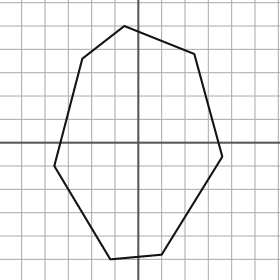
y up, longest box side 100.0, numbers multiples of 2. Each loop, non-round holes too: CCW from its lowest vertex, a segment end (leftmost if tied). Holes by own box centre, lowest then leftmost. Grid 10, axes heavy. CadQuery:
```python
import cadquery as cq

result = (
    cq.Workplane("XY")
    .moveTo(-12.0, -50.0)
    .lineTo(10.0, -48.0)
    .lineTo(36.0, -6.0)
    .lineTo(24.0, 38.0)
    .lineTo(-6.0, 50.0)
    .lineTo(-24.0, 36.0)
    .lineTo(-36.0, -10.0)
    .close()
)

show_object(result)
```